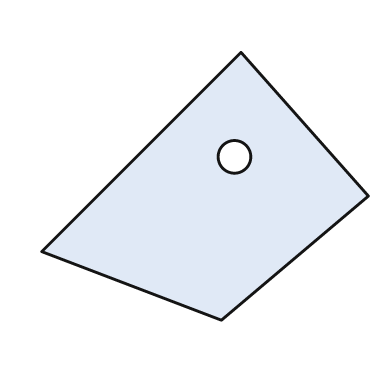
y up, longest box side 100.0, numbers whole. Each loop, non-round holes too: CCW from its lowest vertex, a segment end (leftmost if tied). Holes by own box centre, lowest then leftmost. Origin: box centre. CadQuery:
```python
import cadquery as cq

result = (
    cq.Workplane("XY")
    .moveTo(5.0, -41.0)
    .lineTo(50.0, -3.0)
    .lineTo(11.0, 41.0)
    .lineTo(-50.0, -20.0)
    .close()
    .moveTo(9.0, 9.0)
    .circle(5.0)
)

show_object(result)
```